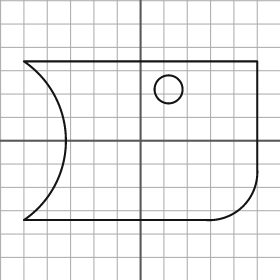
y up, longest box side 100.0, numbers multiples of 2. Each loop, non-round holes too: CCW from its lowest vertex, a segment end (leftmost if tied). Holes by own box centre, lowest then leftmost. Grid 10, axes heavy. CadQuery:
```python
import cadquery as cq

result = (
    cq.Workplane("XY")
    .moveTo(-50.0, -34.0)
    .lineTo(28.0, -34.0)
    .threePointArc((44.0, -28.0), (50.0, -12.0))
    .lineTo(50.0, 34.0)
    .lineTo(-50.0, 34.0)
    .threePointArc((-32.0, 0.0), (-50.0, -34.0))
    .close()
    .moveTo(12.0, 22.0)
    .circle(6.0)
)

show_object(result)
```